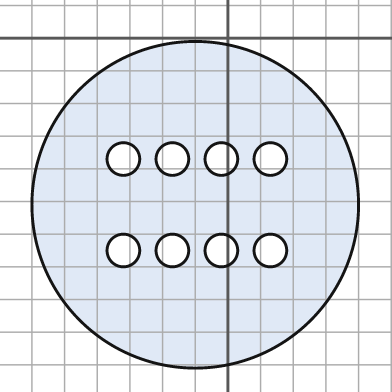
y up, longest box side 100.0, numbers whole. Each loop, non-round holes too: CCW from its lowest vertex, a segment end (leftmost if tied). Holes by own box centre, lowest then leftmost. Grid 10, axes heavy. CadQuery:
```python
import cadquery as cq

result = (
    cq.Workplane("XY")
    .moveTo(-10.0, -51.0)
    .circle(50.0)
    .moveTo(-32.0, -65.0)
    .circle(5.0)
    .moveTo(-17.0, -65.0)
    .circle(5.0)
    .moveTo(-2.0, -65.0)
    .circle(5.0)
    .moveTo(13.0, -65.0)
    .circle(5.0)
    .moveTo(-32.0, -37.0)
    .circle(5.0)
    .moveTo(-17.0, -37.0)
    .circle(5.0)
    .moveTo(-2.0, -37.0)
    .circle(5.0)
    .moveTo(13.0, -37.0)
    .circle(5.0)
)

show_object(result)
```